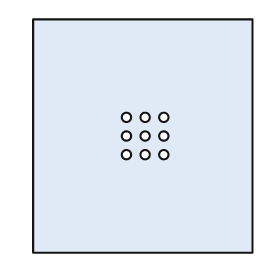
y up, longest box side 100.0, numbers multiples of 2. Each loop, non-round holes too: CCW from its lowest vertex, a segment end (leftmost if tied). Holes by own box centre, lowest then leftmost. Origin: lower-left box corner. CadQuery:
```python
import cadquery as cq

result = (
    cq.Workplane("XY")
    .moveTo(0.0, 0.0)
    .lineTo(94.0, 0.0)
    .lineTo(94.0, 100.0)
    .lineTo(0.0, 100.0)
    .close()
    .moveTo(40.0, 42.0)
    .circle(2.0)
    .moveTo(48.0, 42.0)
    .circle(2.0)
    .moveTo(56.0, 42.0)
    .circle(2.0)
    .moveTo(40.0, 50.0)
    .circle(2.0)
    .moveTo(48.0, 50.0)
    .circle(2.0)
    .moveTo(56.0, 50.0)
    .circle(2.0)
    .moveTo(40.0, 58.0)
    .circle(2.0)
    .moveTo(48.0, 58.0)
    .circle(2.0)
    .moveTo(56.0, 58.0)
    .circle(2.0)
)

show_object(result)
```